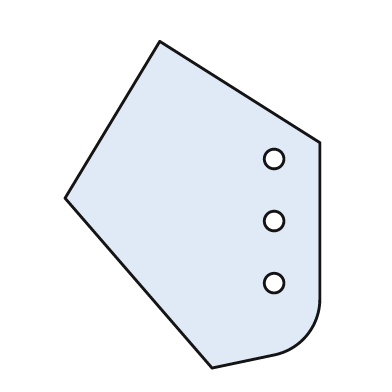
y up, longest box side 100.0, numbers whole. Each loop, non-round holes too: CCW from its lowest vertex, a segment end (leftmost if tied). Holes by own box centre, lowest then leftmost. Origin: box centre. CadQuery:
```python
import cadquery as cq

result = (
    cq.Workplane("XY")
    .moveTo(6.0, -50.0)
    .lineTo(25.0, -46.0)
    .threePointArc((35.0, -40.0), (39.0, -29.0))
    .lineTo(39.0, 19.0)
    .lineTo(-10.0, 50.0)
    .lineTo(-39.0, 2.0)
    .close()
    .moveTo(25.0, -24.0)
    .circle(3.0)
    .moveTo(25.0, -5.0)
    .circle(3.0)
    .moveTo(25.0, 14.0)
    .circle(3.0)
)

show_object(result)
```